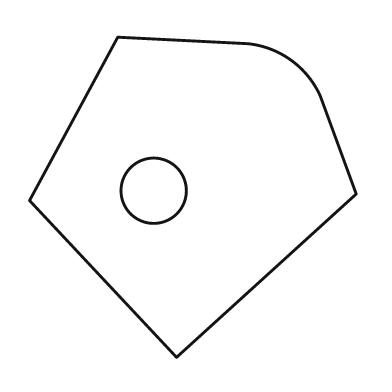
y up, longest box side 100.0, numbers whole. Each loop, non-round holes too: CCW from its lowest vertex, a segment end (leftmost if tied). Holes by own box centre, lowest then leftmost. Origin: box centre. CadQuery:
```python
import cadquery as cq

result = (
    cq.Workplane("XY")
    .moveTo(-5.0, -49.0)
    .lineTo(50.0, 1.0)
    .lineTo(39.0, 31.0)
    .threePointArc((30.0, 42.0), (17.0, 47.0))
    .lineTo(-23.0, 49.0)
    .lineTo(-50.0, -1.0)
    .close()
    .moveTo(-12.0, 2.0)
    .circle(10.0)
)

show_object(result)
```